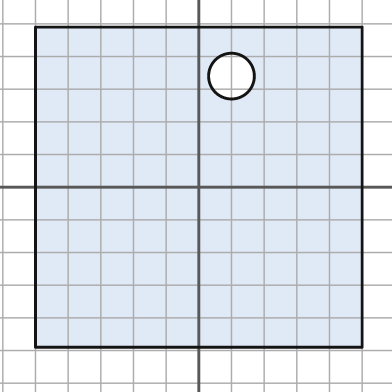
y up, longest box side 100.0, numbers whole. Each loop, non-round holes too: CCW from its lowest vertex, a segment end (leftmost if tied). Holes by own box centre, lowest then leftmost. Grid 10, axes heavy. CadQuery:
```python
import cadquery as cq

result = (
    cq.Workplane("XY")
    .moveTo(-50.0, -49.0)
    .lineTo(50.0, -49.0)
    .lineTo(50.0, 49.0)
    .lineTo(-50.0, 49.0)
    .close()
    .moveTo(10.0, 34.0)
    .circle(7.0)
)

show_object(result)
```